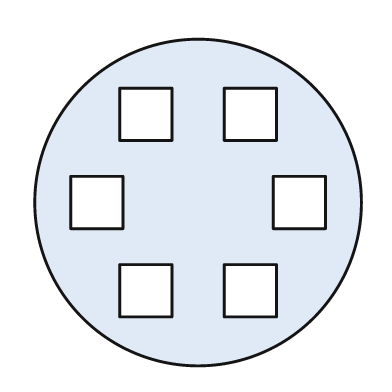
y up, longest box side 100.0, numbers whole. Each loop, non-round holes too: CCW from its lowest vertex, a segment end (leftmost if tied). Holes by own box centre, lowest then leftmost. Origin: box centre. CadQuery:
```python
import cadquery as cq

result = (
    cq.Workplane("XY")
    .moveTo(0.0, 0.0)
    .circle(50.0)
    .moveTo(-24.0, -35.0)
    .lineTo(-8.0, -35.0)
    .lineTo(-8.0, -19.0)
    .lineTo(-24.0, -19.0)
    .close()
    .moveTo(8.0, -35.0)
    .lineTo(24.0, -35.0)
    .lineTo(24.0, -19.0)
    .lineTo(8.0, -19.0)
    .close()
    .moveTo(-39.0, -8.0)
    .lineTo(-23.0, -8.0)
    .lineTo(-23.0, 8.0)
    .lineTo(-39.0, 8.0)
    .close()
    .moveTo(23.0, -8.0)
    .lineTo(39.0, -8.0)
    .lineTo(39.0, 8.0)
    .lineTo(23.0, 8.0)
    .close()
    .moveTo(-24.0, 19.0)
    .lineTo(-8.0, 19.0)
    .lineTo(-8.0, 35.0)
    .lineTo(-24.0, 35.0)
    .close()
    .moveTo(8.0, 19.0)
    .lineTo(24.0, 19.0)
    .lineTo(24.0, 35.0)
    .lineTo(8.0, 35.0)
    .close()
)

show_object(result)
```